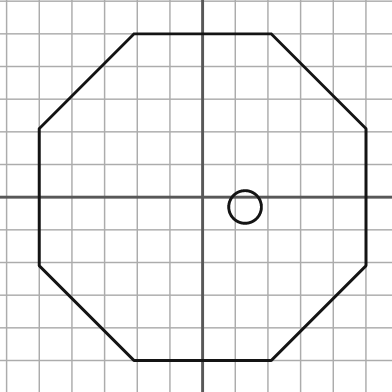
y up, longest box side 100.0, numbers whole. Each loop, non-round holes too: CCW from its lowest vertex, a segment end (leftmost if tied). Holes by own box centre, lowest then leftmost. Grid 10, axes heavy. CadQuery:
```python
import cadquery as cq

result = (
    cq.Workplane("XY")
    .moveTo(-21.0, -50.0)
    .lineTo(21.0, -50.0)
    .lineTo(50.0, -21.0)
    .lineTo(50.0, 21.0)
    .lineTo(21.0, 50.0)
    .lineTo(-21.0, 50.0)
    .lineTo(-50.0, 21.0)
    .lineTo(-50.0, -21.0)
    .close()
    .moveTo(13.0, -3.0)
    .circle(5.0)
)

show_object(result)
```